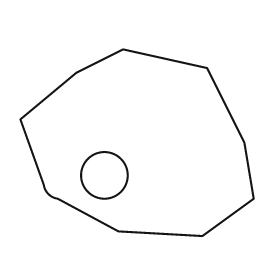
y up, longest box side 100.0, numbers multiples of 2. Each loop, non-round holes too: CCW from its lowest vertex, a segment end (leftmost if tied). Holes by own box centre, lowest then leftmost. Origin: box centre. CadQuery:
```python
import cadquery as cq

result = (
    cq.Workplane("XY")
    .moveTo(28.0, -40.0)
    .lineTo(50.0, -24.0)
    .lineTo(46.0, 0.0)
    .lineTo(30.0, 32.0)
    .lineTo(-6.0, 40.0)
    .lineTo(-26.0, 30.0)
    .lineTo(-50.0, 10.0)
    .lineTo(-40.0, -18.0)
    .threePointArc((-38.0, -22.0), (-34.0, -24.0))
    .lineTo(-8.0, -38.0)
    .close()
    .moveTo(-14.0, -14.0)
    .circle(10.0)
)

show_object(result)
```